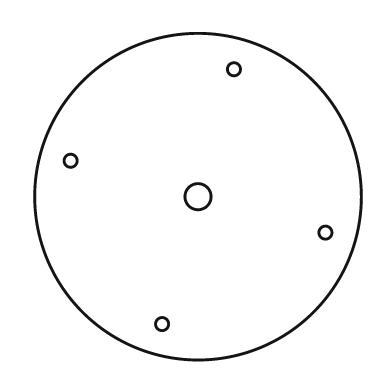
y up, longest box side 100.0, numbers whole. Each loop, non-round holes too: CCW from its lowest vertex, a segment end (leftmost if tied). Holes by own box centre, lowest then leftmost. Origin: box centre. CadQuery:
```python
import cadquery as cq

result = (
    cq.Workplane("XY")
    .moveTo(0.0, 0.0)
    .circle(50.0)
    .moveTo(-11.0, -39.0)
    .circle(2.0)
    .moveTo(39.0, -11.0)
    .circle(2.0)
    .moveTo(0.0, 0.0)
    .circle(4.0)
    .moveTo(-39.0, 11.0)
    .circle(2.0)
    .moveTo(11.0, 39.0)
    .circle(2.0)
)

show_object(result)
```